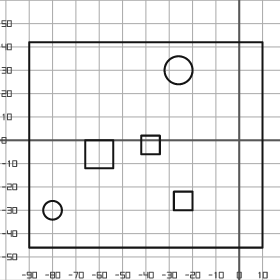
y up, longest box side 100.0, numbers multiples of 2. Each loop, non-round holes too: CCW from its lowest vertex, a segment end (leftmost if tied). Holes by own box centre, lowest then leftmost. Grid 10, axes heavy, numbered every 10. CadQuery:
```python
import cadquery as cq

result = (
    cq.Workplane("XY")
    .moveTo(-90.0, -46.0)
    .lineTo(10.0, -46.0)
    .lineTo(10.0, 42.0)
    .lineTo(-90.0, 42.0)
    .close()
    .moveTo(-80.0, -30.0)
    .circle(4.0)
    .moveTo(-28.0, -30.0)
    .lineTo(-20.0, -30.0)
    .lineTo(-20.0, -22.0)
    .lineTo(-28.0, -22.0)
    .close()
    .moveTo(-66.0, -12.0)
    .lineTo(-54.0, -12.0)
    .lineTo(-54.0, 0.0)
    .lineTo(-66.0, 0.0)
    .close()
    .moveTo(-42.0, -6.0)
    .lineTo(-34.0, -6.0)
    .lineTo(-34.0, 2.0)
    .lineTo(-42.0, 2.0)
    .close()
    .moveTo(-26.0, 30.0)
    .circle(6.0)
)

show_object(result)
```